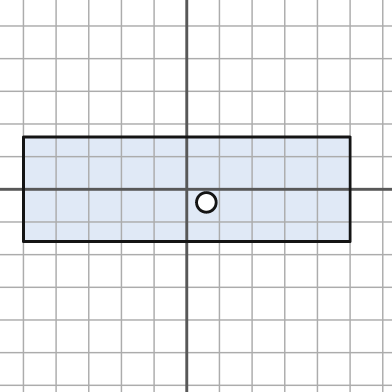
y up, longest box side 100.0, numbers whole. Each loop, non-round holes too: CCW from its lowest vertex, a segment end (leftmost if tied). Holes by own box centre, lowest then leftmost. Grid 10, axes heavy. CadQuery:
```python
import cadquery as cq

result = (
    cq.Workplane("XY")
    .moveTo(-50.0, -16.0)
    .lineTo(50.0, -16.0)
    .lineTo(50.0, 16.0)
    .lineTo(-50.0, 16.0)
    .close()
    .moveTo(6.0, -4.0)
    .circle(3.0)
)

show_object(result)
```